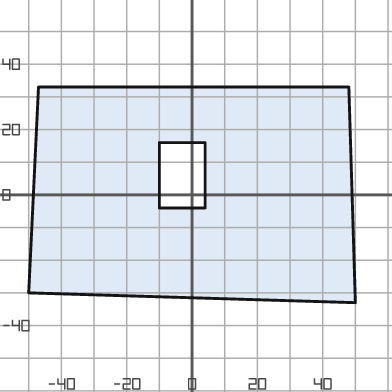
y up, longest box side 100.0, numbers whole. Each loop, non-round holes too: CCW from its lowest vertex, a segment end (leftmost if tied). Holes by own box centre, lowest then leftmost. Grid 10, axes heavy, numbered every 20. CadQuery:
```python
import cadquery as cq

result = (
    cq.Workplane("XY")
    .moveTo(50.0, -33.0)
    .lineTo(48.0, 33.0)
    .lineTo(-47.0, 33.0)
    .lineTo(-50.0, -30.0)
    .close()
    .moveTo(-10.0, -4.0)
    .lineTo(4.0, -4.0)
    .lineTo(4.0, 16.0)
    .lineTo(-10.0, 16.0)
    .close()
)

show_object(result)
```